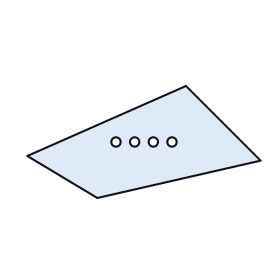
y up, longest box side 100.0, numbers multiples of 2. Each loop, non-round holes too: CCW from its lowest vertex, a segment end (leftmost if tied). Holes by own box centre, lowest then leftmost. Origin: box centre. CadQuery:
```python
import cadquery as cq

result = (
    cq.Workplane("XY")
    .moveTo(-20.0, -24.0)
    .lineTo(50.0, -8.0)
    .lineTo(18.0, 24.0)
    .lineTo(-50.0, -6.0)
    .close()
    .moveTo(-12.0, 0.0)
    .circle(2.0)
    .moveTo(-4.0, 0.0)
    .circle(2.0)
    .moveTo(4.0, 0.0)
    .circle(2.0)
    .moveTo(12.0, 0.0)
    .circle(2.0)
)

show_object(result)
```